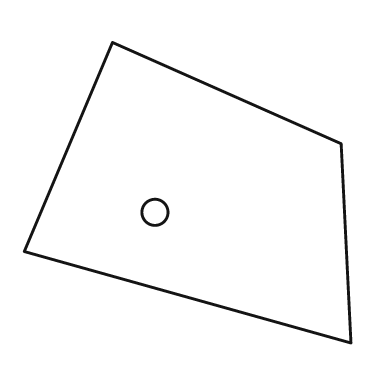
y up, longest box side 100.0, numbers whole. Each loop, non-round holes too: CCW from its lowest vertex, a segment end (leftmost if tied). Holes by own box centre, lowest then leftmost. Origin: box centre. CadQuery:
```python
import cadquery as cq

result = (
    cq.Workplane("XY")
    .moveTo(50.0, -46.0)
    .lineTo(47.0, 15.0)
    .lineTo(-23.0, 46.0)
    .lineTo(-50.0, -18.0)
    .close()
    .moveTo(-10.0, -6.0)
    .circle(4.0)
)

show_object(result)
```